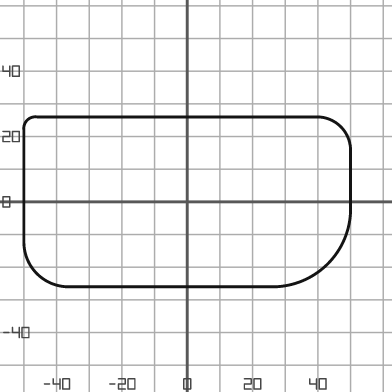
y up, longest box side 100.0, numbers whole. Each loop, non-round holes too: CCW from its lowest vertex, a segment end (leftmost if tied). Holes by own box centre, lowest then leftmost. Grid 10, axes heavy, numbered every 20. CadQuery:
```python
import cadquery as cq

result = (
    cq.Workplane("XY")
    .moveTo(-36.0, -26.0)
    .lineTo(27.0, -26.0)
    .threePointArc((43.0, -19.0), (50.0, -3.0))
    .lineTo(50.0, 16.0)
    .threePointArc((47.0, 23.0), (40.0, 26.0))
    .lineTo(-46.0, 26.0)
    .threePointArc((-49.0, 25.0), (-50.0, 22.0))
    .lineTo(-50.0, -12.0)
    .threePointArc((-46.0, -22.0), (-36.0, -26.0))
    .close()
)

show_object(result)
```